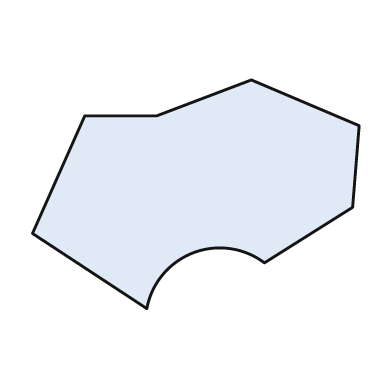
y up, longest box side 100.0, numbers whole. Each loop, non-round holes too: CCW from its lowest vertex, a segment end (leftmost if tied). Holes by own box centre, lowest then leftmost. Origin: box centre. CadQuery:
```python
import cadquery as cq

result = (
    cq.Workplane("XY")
    .moveTo(-15.0, -35.0)
    .threePointArc((-1.0, -18.0), (21.0, -21.0))
    .lineTo(48.0, -4.0)
    .lineTo(50.0, 21.0)
    .lineTo(17.0, 35.0)
    .lineTo(-12.0, 24.0)
    .lineTo(-34.0, 24.0)
    .lineTo(-50.0, -12.0)
    .close()
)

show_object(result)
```